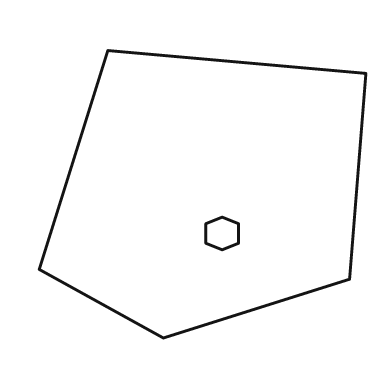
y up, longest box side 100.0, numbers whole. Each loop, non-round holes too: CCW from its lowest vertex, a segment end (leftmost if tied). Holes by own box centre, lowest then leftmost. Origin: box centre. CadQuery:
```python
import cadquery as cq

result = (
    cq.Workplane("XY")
    .moveTo(-12.0, -44.0)
    .lineTo(45.0, -26.0)
    .lineTo(50.0, 37.0)
    .lineTo(-29.0, 44.0)
    .lineTo(-50.0, -23.0)
    .close()
    .moveTo(6.0, -17.0)
    .lineTo(11.0, -15.0)
    .lineTo(11.0, -9.0)
    .lineTo(6.0, -7.0)
    .lineTo(1.0, -9.0)
    .lineTo(1.0, -15.0)
    .close()
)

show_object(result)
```